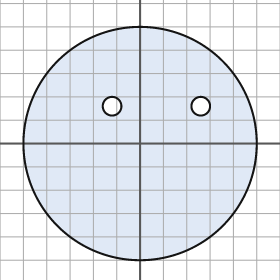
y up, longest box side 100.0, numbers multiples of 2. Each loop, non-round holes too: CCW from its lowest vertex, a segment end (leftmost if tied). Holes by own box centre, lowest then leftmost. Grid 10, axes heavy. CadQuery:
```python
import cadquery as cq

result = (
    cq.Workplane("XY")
    .moveTo(0.0, 0.0)
    .circle(50.0)
    .moveTo(-12.0, 16.0)
    .circle(4.0)
    .moveTo(26.0, 16.0)
    .circle(4.0)
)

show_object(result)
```